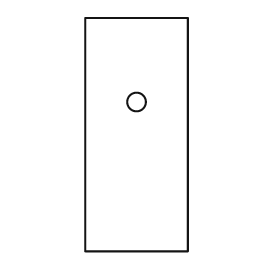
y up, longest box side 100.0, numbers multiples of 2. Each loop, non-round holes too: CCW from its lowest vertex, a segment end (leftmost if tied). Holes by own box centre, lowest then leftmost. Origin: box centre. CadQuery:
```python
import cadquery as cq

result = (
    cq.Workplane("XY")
    .moveTo(-22.0, -50.0)
    .lineTo(22.0, -50.0)
    .lineTo(22.0, 50.0)
    .lineTo(-22.0, 50.0)
    .close()
    .moveTo(0.0, 14.0)
    .circle(4.0)
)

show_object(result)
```